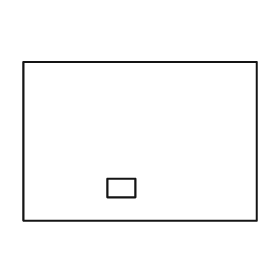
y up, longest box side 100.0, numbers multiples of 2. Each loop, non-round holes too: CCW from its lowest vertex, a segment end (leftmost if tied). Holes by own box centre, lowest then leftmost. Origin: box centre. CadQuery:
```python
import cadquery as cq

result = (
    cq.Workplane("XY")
    .moveTo(-50.0, -34.0)
    .lineTo(50.0, -34.0)
    .lineTo(50.0, 34.0)
    .lineTo(-50.0, 34.0)
    .close()
    .moveTo(-14.0, -24.0)
    .lineTo(-2.0, -24.0)
    .lineTo(-2.0, -16.0)
    .lineTo(-14.0, -16.0)
    .close()
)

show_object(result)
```